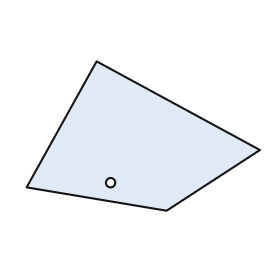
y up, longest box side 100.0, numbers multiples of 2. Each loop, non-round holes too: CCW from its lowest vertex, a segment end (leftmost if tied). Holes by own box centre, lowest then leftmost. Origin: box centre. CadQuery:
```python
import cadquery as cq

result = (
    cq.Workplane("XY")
    .moveTo(10.0, -32.0)
    .lineTo(50.0, -6.0)
    .lineTo(-20.0, 32.0)
    .lineTo(-50.0, -22.0)
    .close()
    .moveTo(-14.0, -20.0)
    .circle(2.0)
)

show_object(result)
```